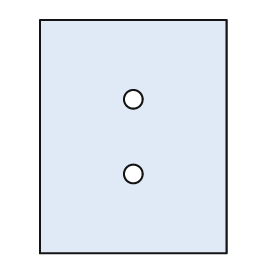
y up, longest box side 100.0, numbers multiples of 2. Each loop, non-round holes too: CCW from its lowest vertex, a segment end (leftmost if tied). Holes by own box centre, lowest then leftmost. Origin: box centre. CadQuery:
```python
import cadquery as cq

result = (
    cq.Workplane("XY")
    .moveTo(-40.0, -50.0)
    .lineTo(40.0, -50.0)
    .lineTo(40.0, 50.0)
    .lineTo(-40.0, 50.0)
    .close()
    .moveTo(0.0, -16.0)
    .circle(4.0)
    .moveTo(0.0, 16.0)
    .circle(4.0)
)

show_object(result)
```